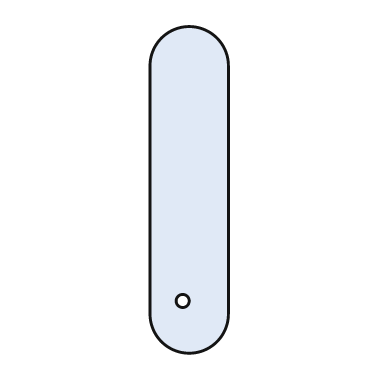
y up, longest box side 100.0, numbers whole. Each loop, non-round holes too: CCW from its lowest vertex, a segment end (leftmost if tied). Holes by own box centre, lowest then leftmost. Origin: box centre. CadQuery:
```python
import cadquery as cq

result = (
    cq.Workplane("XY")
    .moveTo(-12.0, -38.0)
    .threePointArc((0.0, -50.0), (12.0, -38.0))
    .lineTo(12.0, 38.0)
    .threePointArc((0.0, 50.0), (-12.0, 38.0))
    .close()
    .moveTo(-2.0, -34.0)
    .circle(2.0)
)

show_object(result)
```